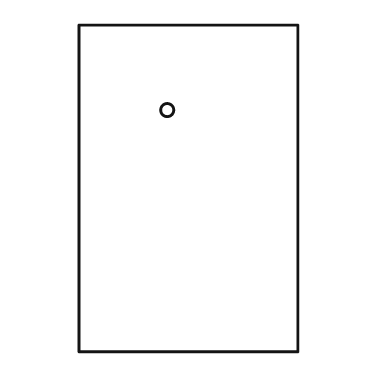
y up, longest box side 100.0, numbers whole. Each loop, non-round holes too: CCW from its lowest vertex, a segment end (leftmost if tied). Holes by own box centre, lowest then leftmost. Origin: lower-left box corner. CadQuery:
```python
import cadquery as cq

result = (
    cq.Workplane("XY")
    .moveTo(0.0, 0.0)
    .lineTo(67.0, 0.0)
    .lineTo(67.0, 100.0)
    .lineTo(0.0, 100.0)
    .close()
    .moveTo(27.0, 74.0)
    .circle(2.0)
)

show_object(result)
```